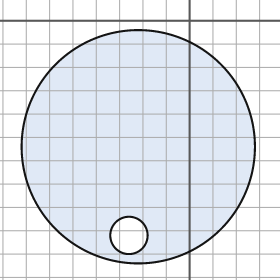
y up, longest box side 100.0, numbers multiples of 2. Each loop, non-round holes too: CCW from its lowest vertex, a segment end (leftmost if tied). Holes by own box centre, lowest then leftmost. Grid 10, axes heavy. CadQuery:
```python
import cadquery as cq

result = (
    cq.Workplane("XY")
    .moveTo(-22.0, -54.0)
    .circle(50.0)
    .moveTo(-26.0, -92.0)
    .circle(8.0)
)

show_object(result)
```